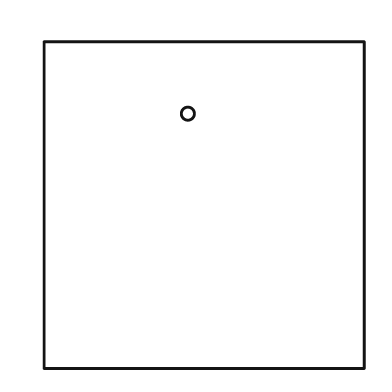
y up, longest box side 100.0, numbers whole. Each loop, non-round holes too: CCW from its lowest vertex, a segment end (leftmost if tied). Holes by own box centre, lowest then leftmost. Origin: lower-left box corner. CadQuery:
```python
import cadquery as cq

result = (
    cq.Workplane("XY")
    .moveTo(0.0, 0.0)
    .lineTo(98.0, 0.0)
    .lineTo(98.0, 100.0)
    .lineTo(0.0, 100.0)
    .close()
    .moveTo(44.0, 78.0)
    .circle(2.0)
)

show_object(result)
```